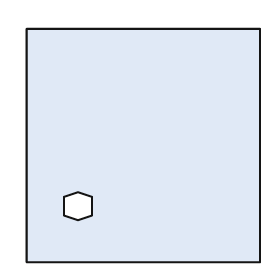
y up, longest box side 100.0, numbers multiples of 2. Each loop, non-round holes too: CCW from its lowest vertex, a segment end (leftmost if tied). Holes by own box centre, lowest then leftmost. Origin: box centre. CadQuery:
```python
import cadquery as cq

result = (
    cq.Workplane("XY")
    .moveTo(-50.0, -50.0)
    .lineTo(50.0, -50.0)
    .lineTo(50.0, 50.0)
    .lineTo(-50.0, 50.0)
    .close()
    .moveTo(-28.0, -32.0)
    .lineTo(-22.0, -30.0)
    .lineTo(-22.0, -22.0)
    .lineTo(-28.0, -20.0)
    .lineTo(-34.0, -22.0)
    .lineTo(-34.0, -30.0)
    .close()
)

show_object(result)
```